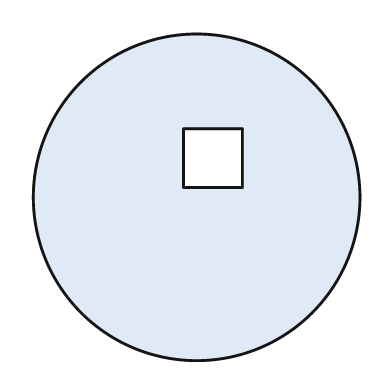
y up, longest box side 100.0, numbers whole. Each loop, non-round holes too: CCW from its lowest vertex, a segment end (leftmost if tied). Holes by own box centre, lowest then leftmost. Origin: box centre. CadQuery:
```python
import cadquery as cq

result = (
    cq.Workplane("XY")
    .moveTo(0.0, 0.0)
    .circle(50.0)
    .moveTo(-4.0, 3.0)
    .lineTo(14.0, 3.0)
    .lineTo(14.0, 21.0)
    .lineTo(-4.0, 21.0)
    .close()
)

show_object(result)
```